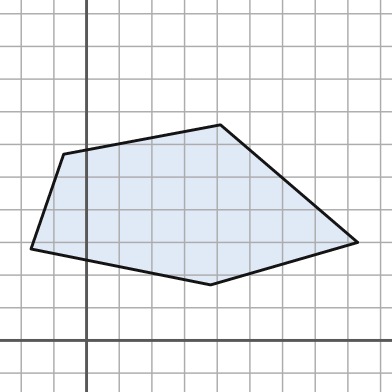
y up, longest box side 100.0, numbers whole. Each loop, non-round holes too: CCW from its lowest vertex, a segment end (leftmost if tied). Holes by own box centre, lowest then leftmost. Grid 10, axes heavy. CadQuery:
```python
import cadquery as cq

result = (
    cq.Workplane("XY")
    .moveTo(38.0, 17.0)
    .lineTo(83.0, 30.0)
    .lineTo(41.0, 66.0)
    .lineTo(-7.0, 57.0)
    .lineTo(-17.0, 28.0)
    .close()
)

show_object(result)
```